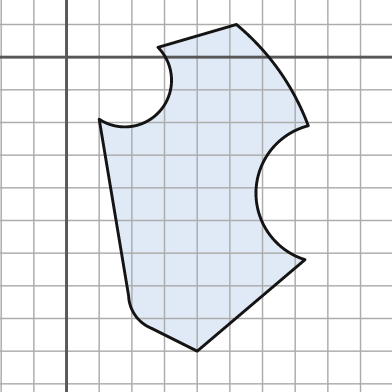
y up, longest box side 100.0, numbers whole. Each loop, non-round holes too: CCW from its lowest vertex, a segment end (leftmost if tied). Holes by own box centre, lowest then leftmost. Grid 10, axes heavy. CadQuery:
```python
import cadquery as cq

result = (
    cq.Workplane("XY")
    .moveTo(40.0, -90.0)
    .lineTo(73.0, -62.0)
    .threePointArc((58.0, -41.0), (74.0, -21.0))
    .threePointArc((65.0, -4.0), (52.0, 10.0))
    .lineTo(28.0, 3.0)
    .threePointArc((29.0, -16.0), (10.0, -19.0))
    .lineTo(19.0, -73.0)
    .threePointArc((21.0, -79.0), (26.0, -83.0))
    .close()
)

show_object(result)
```